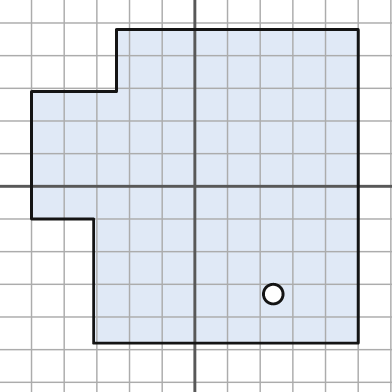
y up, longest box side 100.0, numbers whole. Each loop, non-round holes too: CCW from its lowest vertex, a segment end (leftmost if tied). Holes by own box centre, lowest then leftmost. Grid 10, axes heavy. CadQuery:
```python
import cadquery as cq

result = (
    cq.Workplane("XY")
    .moveTo(-31.0, -48.0)
    .lineTo(50.0, -48.0)
    .lineTo(50.0, 48.0)
    .lineTo(-24.0, 48.0)
    .lineTo(-24.0, 29.0)
    .lineTo(-50.0, 29.0)
    .lineTo(-50.0, -10.0)
    .lineTo(-31.0, -10.0)
    .close()
    .moveTo(24.0, -33.0)
    .circle(3.0)
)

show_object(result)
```